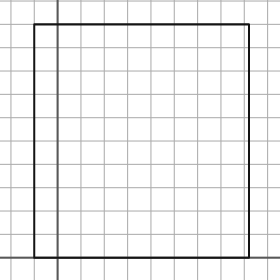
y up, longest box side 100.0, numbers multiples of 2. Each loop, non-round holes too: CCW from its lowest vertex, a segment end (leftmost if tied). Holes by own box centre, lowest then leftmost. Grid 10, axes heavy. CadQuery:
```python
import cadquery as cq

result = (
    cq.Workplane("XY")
    .moveTo(-10.0, 0.0)
    .lineTo(82.0, 0.0)
    .lineTo(82.0, 100.0)
    .lineTo(-10.0, 100.0)
    .close()
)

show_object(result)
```